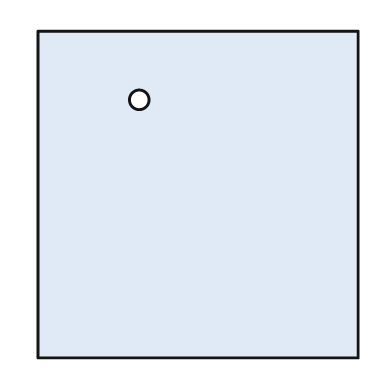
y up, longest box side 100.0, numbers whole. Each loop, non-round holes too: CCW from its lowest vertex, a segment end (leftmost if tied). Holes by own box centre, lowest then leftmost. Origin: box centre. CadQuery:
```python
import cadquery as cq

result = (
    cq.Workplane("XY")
    .moveTo(-49.0, -50.0)
    .lineTo(49.0, -50.0)
    .lineTo(49.0, 50.0)
    .lineTo(-49.0, 50.0)
    .close()
    .moveTo(-18.0, 29.0)
    .circle(3.0)
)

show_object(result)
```